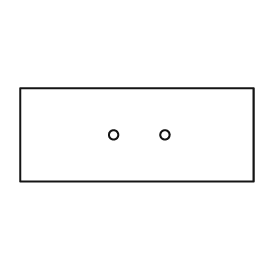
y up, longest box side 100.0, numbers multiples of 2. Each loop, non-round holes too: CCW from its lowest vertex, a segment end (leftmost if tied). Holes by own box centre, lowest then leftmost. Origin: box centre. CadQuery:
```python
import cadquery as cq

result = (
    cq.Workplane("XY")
    .moveTo(-50.0, -20.0)
    .lineTo(50.0, -20.0)
    .lineTo(50.0, 20.0)
    .lineTo(-50.0, 20.0)
    .close()
    .moveTo(-10.0, 0.0)
    .circle(2.0)
    .moveTo(12.0, 0.0)
    .circle(2.0)
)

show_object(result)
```